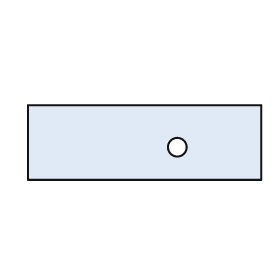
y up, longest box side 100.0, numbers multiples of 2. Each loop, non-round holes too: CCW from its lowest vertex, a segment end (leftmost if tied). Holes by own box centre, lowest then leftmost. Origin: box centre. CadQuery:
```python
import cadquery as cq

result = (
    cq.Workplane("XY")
    .moveTo(-50.0, -16.0)
    .lineTo(50.0, -16.0)
    .lineTo(50.0, 16.0)
    .lineTo(-50.0, 16.0)
    .close()
    .moveTo(14.0, -2.0)
    .circle(4.0)
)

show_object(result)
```